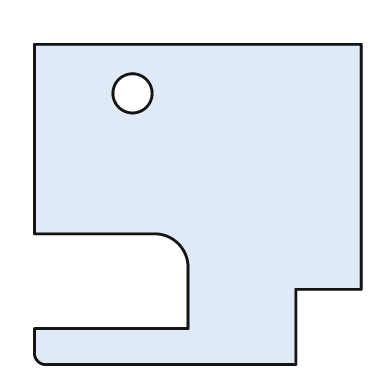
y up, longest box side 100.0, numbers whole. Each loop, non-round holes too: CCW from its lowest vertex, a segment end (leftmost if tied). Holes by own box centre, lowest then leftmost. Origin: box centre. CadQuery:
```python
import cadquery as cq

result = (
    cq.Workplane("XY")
    .moveTo(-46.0, -49.0)
    .lineTo(30.0, -49.0)
    .lineTo(30.0, -26.0)
    .lineTo(50.0, -26.0)
    .lineTo(50.0, 49.0)
    .lineTo(-50.0, 49.0)
    .lineTo(-50.0, -9.0)
    .lineTo(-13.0, -9.0)
    .threePointArc((-6.0, -12.0), (-3.0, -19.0))
    .lineTo(-3.0, -38.0)
    .lineTo(-50.0, -38.0)
    .lineTo(-50.0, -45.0)
    .threePointArc((-49.0, -48.0), (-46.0, -49.0))
    .close()
    .moveTo(-20.0, 34.0)
    .circle(6.0)
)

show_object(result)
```